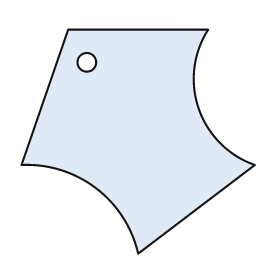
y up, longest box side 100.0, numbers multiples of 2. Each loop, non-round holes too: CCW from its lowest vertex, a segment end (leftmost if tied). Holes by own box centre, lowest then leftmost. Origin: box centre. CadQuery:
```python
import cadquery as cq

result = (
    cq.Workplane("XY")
    .moveTo(0.0, -48.0)
    .lineTo(50.0, -10.0)
    .threePointArc((26.0, 14.0), (30.0, 48.0))
    .lineTo(-30.0, 48.0)
    .lineTo(-50.0, -10.0)
    .threePointArc((-18.0, -20.0), (0.0, -48.0))
    .close()
    .moveTo(-22.0, 34.0)
    .circle(4.0)
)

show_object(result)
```